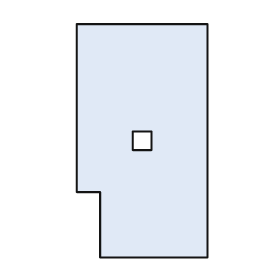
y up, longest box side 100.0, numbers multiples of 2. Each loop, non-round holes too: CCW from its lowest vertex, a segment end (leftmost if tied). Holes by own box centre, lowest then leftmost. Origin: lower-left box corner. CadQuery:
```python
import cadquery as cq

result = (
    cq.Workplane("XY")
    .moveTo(10.0, 0.0)
    .lineTo(56.0, 0.0)
    .lineTo(56.0, 100.0)
    .lineTo(0.0, 100.0)
    .lineTo(0.0, 28.0)
    .lineTo(10.0, 28.0)
    .close()
    .moveTo(24.0, 46.0)
    .lineTo(32.0, 46.0)
    .lineTo(32.0, 54.0)
    .lineTo(24.0, 54.0)
    .close()
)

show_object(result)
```